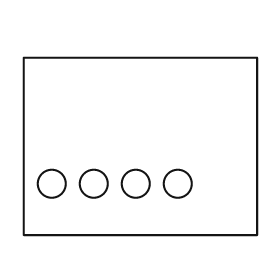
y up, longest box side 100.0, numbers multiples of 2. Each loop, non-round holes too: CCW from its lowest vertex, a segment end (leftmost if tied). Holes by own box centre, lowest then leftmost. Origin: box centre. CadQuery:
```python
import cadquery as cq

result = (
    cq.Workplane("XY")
    .moveTo(-50.0, -38.0)
    .lineTo(50.0, -38.0)
    .lineTo(50.0, 38.0)
    .lineTo(-50.0, 38.0)
    .close()
    .moveTo(-38.0, -16.0)
    .circle(6.0)
    .moveTo(-20.0, -16.0)
    .circle(6.0)
    .moveTo(-2.0, -16.0)
    .circle(6.0)
    .moveTo(16.0, -16.0)
    .circle(6.0)
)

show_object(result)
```